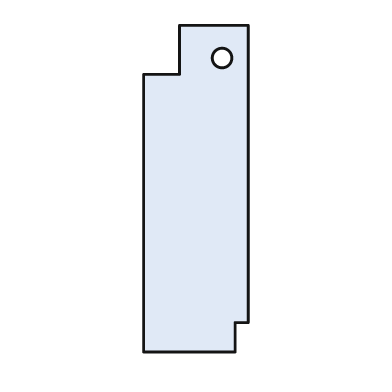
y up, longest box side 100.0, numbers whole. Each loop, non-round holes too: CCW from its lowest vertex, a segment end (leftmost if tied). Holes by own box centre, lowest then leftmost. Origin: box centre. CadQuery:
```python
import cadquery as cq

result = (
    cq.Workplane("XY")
    .moveTo(-16.0, -50.0)
    .lineTo(12.0, -50.0)
    .lineTo(12.0, -41.0)
    .lineTo(16.0, -41.0)
    .lineTo(16.0, 50.0)
    .lineTo(-5.0, 50.0)
    .lineTo(-5.0, 35.0)
    .lineTo(-16.0, 35.0)
    .close()
    .moveTo(8.0, 40.0)
    .circle(3.0)
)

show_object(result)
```